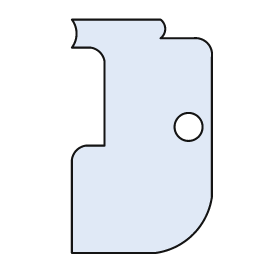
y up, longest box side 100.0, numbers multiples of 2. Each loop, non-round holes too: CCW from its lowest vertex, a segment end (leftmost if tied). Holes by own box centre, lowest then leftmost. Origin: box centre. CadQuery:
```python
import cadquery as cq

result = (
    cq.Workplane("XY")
    .moveTo(-30.0, -50.0)
    .lineTo(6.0, -50.0)
    .threePointArc((22.0, -42.0), (30.0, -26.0))
    .lineTo(30.0, 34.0)
    .threePointArc((28.0, 40.0), (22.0, 42.0))
    .lineTo(8.0, 42.0)
    .threePointArc((10.0, 46.0), (8.0, 50.0))
    .lineTo(-30.0, 50.0)
    .threePointArc((-28.0, 44.0), (-30.0, 38.0))
    .lineTo(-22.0, 38.0)
    .threePointArc((-18.0, 36.0), (-16.0, 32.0))
    .lineTo(-16.0, -4.0)
    .lineTo(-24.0, -4.0)
    .threePointArc((-28.0, -6.0), (-30.0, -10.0))
    .close()
    .moveTo(20.0, 4.0)
    .circle(6.0)
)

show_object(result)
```